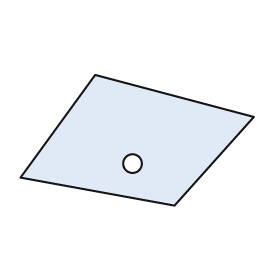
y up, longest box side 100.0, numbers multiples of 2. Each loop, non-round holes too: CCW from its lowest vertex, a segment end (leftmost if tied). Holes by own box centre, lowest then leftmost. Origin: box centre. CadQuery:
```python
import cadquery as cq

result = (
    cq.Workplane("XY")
    .moveTo(16.0, -28.0)
    .lineTo(50.0, 10.0)
    .lineTo(-18.0, 28.0)
    .lineTo(-50.0, -16.0)
    .close()
    .moveTo(-2.0, -10.0)
    .circle(4.0)
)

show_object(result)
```